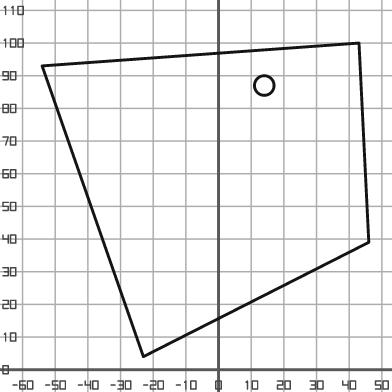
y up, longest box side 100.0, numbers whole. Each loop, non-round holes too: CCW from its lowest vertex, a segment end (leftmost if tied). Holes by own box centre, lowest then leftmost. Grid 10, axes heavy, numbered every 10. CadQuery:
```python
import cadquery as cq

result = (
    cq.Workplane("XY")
    .moveTo(-23.0, 4.0)
    .lineTo(46.0, 39.0)
    .lineTo(43.0, 100.0)
    .lineTo(-54.0, 93.0)
    .close()
    .moveTo(14.0, 87.0)
    .circle(3.0)
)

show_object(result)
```